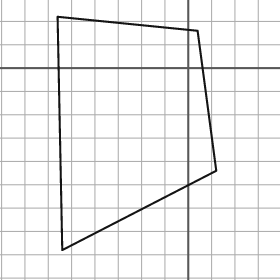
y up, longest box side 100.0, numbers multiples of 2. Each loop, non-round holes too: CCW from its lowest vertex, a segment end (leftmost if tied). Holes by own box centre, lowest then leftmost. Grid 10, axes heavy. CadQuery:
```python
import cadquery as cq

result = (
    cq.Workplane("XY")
    .moveTo(-54.0, -78.0)
    .lineTo(12.0, -44.0)
    .lineTo(4.0, 16.0)
    .lineTo(-56.0, 22.0)
    .close()
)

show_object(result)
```